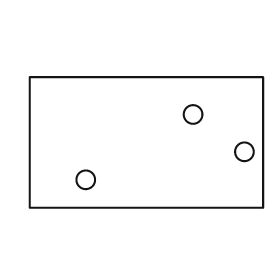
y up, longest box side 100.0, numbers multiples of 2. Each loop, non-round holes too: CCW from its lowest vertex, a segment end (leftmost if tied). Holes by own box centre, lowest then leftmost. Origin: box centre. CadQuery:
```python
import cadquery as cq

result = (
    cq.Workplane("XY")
    .moveTo(-50.0, -28.0)
    .lineTo(50.0, -28.0)
    .lineTo(50.0, 28.0)
    .lineTo(-50.0, 28.0)
    .close()
    .moveTo(-26.0, -16.0)
    .circle(4.0)
    .moveTo(42.0, -4.0)
    .circle(4.0)
    .moveTo(20.0, 12.0)
    .circle(4.0)
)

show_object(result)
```